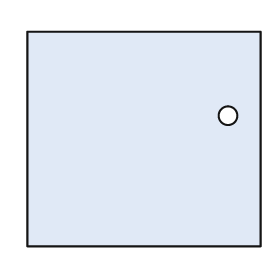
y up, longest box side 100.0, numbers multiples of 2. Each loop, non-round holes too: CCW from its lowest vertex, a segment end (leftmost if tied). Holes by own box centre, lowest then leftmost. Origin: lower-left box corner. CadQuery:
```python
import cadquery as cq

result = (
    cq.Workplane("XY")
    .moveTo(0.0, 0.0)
    .lineTo(100.0, 0.0)
    .lineTo(100.0, 92.0)
    .lineTo(0.0, 92.0)
    .close()
    .moveTo(86.0, 56.0)
    .circle(4.0)
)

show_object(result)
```